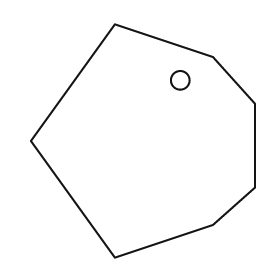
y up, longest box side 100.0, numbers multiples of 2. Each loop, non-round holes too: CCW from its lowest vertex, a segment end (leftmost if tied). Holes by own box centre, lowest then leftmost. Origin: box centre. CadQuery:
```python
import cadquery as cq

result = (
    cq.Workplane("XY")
    .moveTo(-12.0, -50.0)
    .lineTo(30.0, -36.0)
    .lineTo(48.0, -20.0)
    .lineTo(48.0, 16.0)
    .lineTo(30.0, 36.0)
    .lineTo(-12.0, 50.0)
    .lineTo(-48.0, 0.0)
    .close()
    .moveTo(16.0, 26.0)
    .circle(4.0)
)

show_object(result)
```